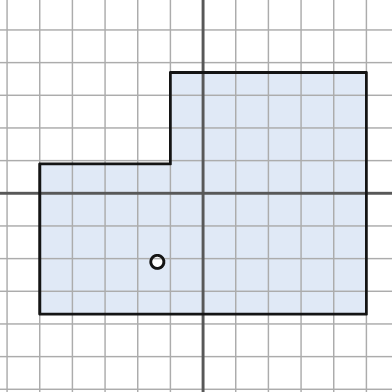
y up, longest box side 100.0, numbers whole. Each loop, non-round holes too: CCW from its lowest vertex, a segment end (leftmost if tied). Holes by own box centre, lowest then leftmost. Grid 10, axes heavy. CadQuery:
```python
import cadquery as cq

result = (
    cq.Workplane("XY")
    .moveTo(-50.0, -37.0)
    .lineTo(50.0, -37.0)
    .lineTo(50.0, 37.0)
    .lineTo(-10.0, 37.0)
    .lineTo(-10.0, 9.0)
    .lineTo(-50.0, 9.0)
    .close()
    .moveTo(-14.0, -21.0)
    .circle(2.0)
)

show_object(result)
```